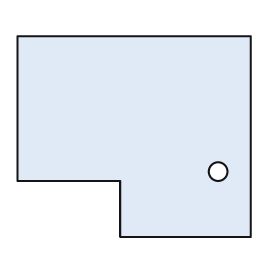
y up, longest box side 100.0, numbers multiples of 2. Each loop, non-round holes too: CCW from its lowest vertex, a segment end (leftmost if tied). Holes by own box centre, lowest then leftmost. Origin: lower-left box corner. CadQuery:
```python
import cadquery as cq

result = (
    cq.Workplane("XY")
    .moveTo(44.0, 0.0)
    .lineTo(100.0, 0.0)
    .lineTo(100.0, 86.0)
    .lineTo(0.0, 86.0)
    .lineTo(0.0, 24.0)
    .lineTo(44.0, 24.0)
    .close()
    .moveTo(86.0, 28.0)
    .circle(4.0)
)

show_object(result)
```